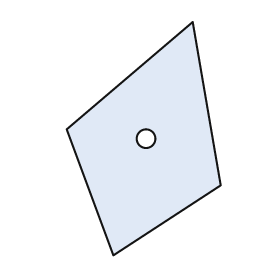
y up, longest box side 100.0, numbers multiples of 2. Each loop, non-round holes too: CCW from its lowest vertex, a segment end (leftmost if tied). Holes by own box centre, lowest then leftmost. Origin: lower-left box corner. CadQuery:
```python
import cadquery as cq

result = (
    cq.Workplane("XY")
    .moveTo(20.0, 0.0)
    .lineTo(66.0, 30.0)
    .lineTo(54.0, 100.0)
    .lineTo(0.0, 54.0)
    .close()
    .moveTo(34.0, 50.0)
    .circle(4.0)
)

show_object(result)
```